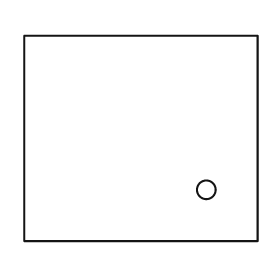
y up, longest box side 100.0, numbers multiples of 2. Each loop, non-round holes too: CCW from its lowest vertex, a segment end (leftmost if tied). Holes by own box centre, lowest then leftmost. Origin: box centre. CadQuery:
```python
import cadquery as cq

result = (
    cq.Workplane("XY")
    .moveTo(-50.0, -44.0)
    .lineTo(50.0, -44.0)
    .lineTo(50.0, 44.0)
    .lineTo(-50.0, 44.0)
    .close()
    .moveTo(28.0, -22.0)
    .circle(4.0)
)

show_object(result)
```